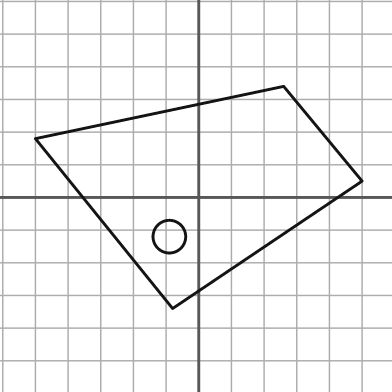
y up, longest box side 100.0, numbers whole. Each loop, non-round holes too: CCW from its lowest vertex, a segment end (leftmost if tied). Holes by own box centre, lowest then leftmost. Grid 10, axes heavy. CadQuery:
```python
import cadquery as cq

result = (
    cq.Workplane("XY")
    .moveTo(-8.0, -34.0)
    .lineTo(50.0, 5.0)
    .lineTo(26.0, 34.0)
    .lineTo(-50.0, 18.0)
    .close()
    .moveTo(-9.0, -12.0)
    .circle(5.0)
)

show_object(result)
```